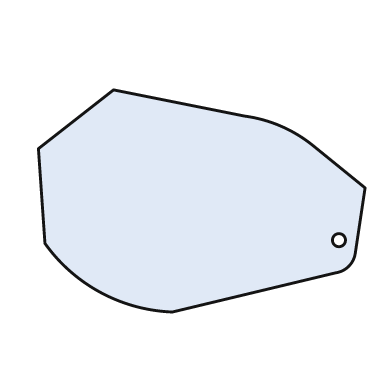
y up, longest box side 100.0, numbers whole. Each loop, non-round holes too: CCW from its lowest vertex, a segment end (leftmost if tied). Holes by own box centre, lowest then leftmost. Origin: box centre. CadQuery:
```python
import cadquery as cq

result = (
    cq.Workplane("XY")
    .moveTo(-9.0, -34.0)
    .lineTo(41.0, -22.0)
    .threePointArc((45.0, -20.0), (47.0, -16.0))
    .lineTo(50.0, 4.0)
    .lineTo(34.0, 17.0)
    .threePointArc((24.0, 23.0), (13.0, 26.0))
    .lineTo(-27.0, 34.0)
    .lineTo(-50.0, 16.0)
    .lineTo(-48.0, -13.0)
    .threePointArc((-31.0, -28.0), (-9.0, -34.0))
    .close()
    .moveTo(42.0, -12.0)
    .circle(2.0)
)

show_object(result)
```